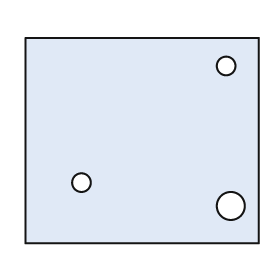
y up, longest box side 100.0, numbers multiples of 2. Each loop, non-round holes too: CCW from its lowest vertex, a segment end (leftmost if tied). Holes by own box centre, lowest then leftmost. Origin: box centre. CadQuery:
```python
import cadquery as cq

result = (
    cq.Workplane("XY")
    .moveTo(-50.0, -44.0)
    .lineTo(50.0, -44.0)
    .lineTo(50.0, 44.0)
    .lineTo(-50.0, 44.0)
    .close()
    .moveTo(38.0, -28.0)
    .circle(6.0)
    .moveTo(-26.0, -18.0)
    .circle(4.0)
    .moveTo(36.0, 32.0)
    .circle(4.0)
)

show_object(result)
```